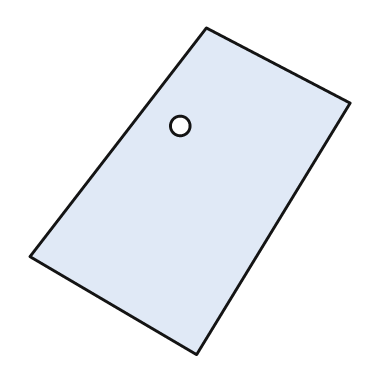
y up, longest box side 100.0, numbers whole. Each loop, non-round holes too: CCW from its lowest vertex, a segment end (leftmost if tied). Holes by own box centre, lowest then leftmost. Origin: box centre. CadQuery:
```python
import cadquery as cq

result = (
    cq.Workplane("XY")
    .moveTo(2.0, -50.0)
    .lineTo(49.0, 27.0)
    .lineTo(5.0, 50.0)
    .lineTo(-49.0, -20.0)
    .close()
    .moveTo(-3.0, 20.0)
    .circle(3.0)
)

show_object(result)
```